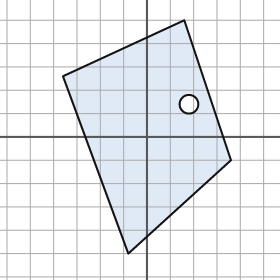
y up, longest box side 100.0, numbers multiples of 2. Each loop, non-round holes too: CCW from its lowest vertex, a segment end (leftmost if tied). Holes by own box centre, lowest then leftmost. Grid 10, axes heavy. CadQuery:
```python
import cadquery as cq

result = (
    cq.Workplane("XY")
    .moveTo(-8.0, -50.0)
    .lineTo(36.0, -10.0)
    .lineTo(16.0, 50.0)
    .lineTo(-36.0, 26.0)
    .close()
    .moveTo(18.0, 14.0)
    .circle(4.0)
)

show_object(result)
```